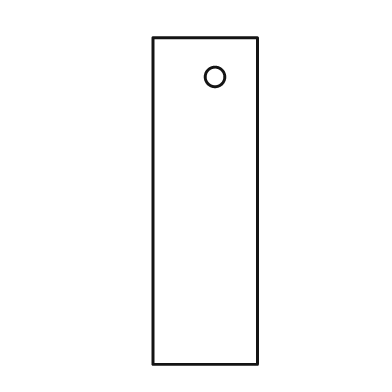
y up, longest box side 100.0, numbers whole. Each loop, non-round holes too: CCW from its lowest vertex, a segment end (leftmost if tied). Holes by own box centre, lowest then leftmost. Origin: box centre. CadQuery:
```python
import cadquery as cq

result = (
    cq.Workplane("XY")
    .moveTo(-16.0, -50.0)
    .lineTo(16.0, -50.0)
    .lineTo(16.0, 50.0)
    .lineTo(-16.0, 50.0)
    .close()
    .moveTo(3.0, 38.0)
    .circle(3.0)
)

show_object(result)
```